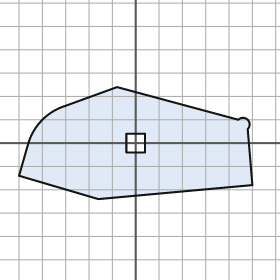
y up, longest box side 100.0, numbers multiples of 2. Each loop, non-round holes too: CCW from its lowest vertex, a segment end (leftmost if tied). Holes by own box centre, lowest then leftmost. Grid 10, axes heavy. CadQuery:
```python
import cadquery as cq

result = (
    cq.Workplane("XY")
    .moveTo(-16.0, -24.0)
    .lineTo(50.0, -18.0)
    .lineTo(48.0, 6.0)
    .threePointArc((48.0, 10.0), (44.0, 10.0))
    .lineTo(-8.0, 24.0)
    .lineTo(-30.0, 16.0)
    .threePointArc((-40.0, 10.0), (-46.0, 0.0))
    .lineTo(-50.0, -14.0)
    .close()
    .moveTo(-4.0, -4.0)
    .lineTo(4.0, -4.0)
    .lineTo(4.0, 4.0)
    .lineTo(-4.0, 4.0)
    .close()
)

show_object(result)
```